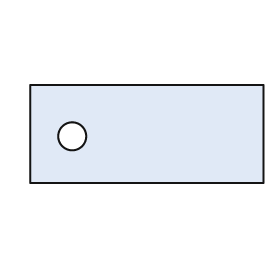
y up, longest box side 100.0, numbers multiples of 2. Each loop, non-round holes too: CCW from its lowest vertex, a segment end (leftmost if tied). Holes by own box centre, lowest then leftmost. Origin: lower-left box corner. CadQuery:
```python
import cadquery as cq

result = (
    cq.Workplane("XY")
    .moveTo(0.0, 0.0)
    .lineTo(100.0, 0.0)
    .lineTo(100.0, 42.0)
    .lineTo(0.0, 42.0)
    .close()
    .moveTo(18.0, 20.0)
    .circle(6.0)
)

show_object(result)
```